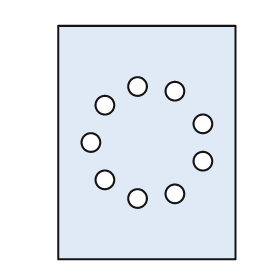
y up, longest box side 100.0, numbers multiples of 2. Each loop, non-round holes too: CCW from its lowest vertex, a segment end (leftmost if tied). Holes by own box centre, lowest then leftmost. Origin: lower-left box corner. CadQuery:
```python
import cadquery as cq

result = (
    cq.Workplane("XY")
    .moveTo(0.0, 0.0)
    .lineTo(76.0, 0.0)
    .lineTo(76.0, 100.0)
    .lineTo(0.0, 100.0)
    .close()
    .moveTo(34.0, 26.0)
    .circle(4.0)
    .moveTo(50.0, 28.0)
    .circle(4.0)
    .moveTo(20.0, 34.0)
    .circle(4.0)
    .moveTo(62.0, 42.0)
    .circle(4.0)
    .moveTo(14.0, 50.0)
    .circle(4.0)
    .moveTo(62.0, 58.0)
    .circle(4.0)
    .moveTo(20.0, 66.0)
    .circle(4.0)
    .moveTo(50.0, 72.0)
    .circle(4.0)
    .moveTo(34.0, 74.0)
    .circle(4.0)
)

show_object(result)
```